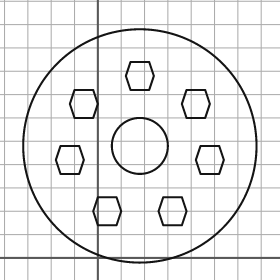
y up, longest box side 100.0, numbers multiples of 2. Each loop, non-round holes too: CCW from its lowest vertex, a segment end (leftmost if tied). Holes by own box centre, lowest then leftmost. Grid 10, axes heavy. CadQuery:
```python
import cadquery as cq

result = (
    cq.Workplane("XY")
    .moveTo(18.0, 48.0)
    .circle(50.0)
    .moveTo(0.0, 14.0)
    .lineTo(8.0, 14.0)
    .lineTo(10.0, 20.0)
    .lineTo(8.0, 26.0)
    .lineTo(0.0, 26.0)
    .lineTo(-2.0, 20.0)
    .close()
    .moveTo(28.0, 14.0)
    .lineTo(36.0, 14.0)
    .lineTo(38.0, 20.0)
    .lineTo(36.0, 26.0)
    .lineTo(28.0, 26.0)
    .lineTo(26.0, 20.0)
    .close()
    .moveTo(-16.0, 36.0)
    .lineTo(-8.0, 36.0)
    .lineTo(-6.0, 42.0)
    .lineTo(-8.0, 48.0)
    .lineTo(-16.0, 48.0)
    .lineTo(-18.0, 42.0)
    .close()
    .moveTo(44.0, 36.0)
    .lineTo(52.0, 36.0)
    .lineTo(54.0, 42.0)
    .lineTo(52.0, 48.0)
    .lineTo(44.0, 48.0)
    .lineTo(42.0, 42.0)
    .close()
    .moveTo(18.0, 48.0)
    .circle(12.0)
    .moveTo(-10.0, 60.0)
    .lineTo(-2.0, 60.0)
    .lineTo(0.0, 66.0)
    .lineTo(-2.0, 72.0)
    .lineTo(-10.0, 72.0)
    .lineTo(-12.0, 66.0)
    .close()
    .moveTo(38.0, 60.0)
    .lineTo(46.0, 60.0)
    .lineTo(48.0, 66.0)
    .lineTo(46.0, 72.0)
    .lineTo(38.0, 72.0)
    .lineTo(36.0, 66.0)
    .close()
    .moveTo(14.0, 72.0)
    .lineTo(22.0, 72.0)
    .lineTo(24.0, 78.0)
    .lineTo(22.0, 84.0)
    .lineTo(14.0, 84.0)
    .lineTo(12.0, 78.0)
    .close()
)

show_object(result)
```